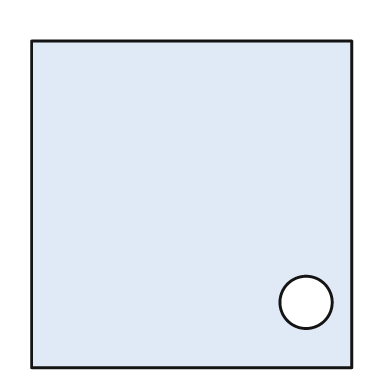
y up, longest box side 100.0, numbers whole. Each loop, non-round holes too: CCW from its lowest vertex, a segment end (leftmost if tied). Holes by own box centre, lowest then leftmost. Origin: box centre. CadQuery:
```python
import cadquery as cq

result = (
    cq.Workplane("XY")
    .moveTo(-49.0, -50.0)
    .lineTo(49.0, -50.0)
    .lineTo(49.0, 50.0)
    .lineTo(-49.0, 50.0)
    .close()
    .moveTo(35.0, -30.0)
    .circle(8.0)
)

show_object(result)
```